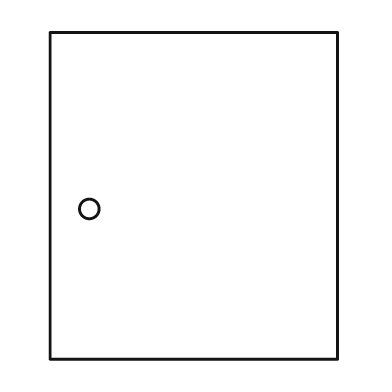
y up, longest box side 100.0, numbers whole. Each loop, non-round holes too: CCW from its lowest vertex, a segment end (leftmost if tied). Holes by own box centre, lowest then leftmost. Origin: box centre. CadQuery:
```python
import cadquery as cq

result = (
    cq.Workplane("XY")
    .moveTo(-44.0, -50.0)
    .lineTo(44.0, -50.0)
    .lineTo(44.0, 50.0)
    .lineTo(-44.0, 50.0)
    .close()
    .moveTo(-32.0, -4.0)
    .circle(3.0)
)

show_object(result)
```